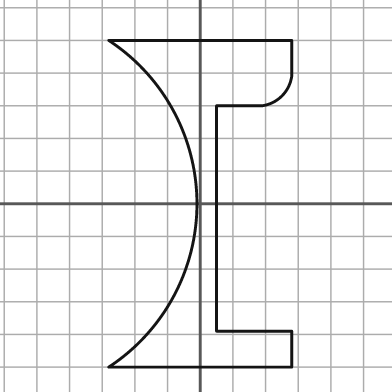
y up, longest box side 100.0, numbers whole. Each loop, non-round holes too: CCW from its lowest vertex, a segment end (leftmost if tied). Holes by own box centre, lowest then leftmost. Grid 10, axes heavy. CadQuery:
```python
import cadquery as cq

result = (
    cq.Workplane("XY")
    .moveTo(-28.0, -50.0)
    .lineTo(28.0, -50.0)
    .lineTo(28.0, -39.0)
    .lineTo(5.0, -39.0)
    .lineTo(5.0, 30.0)
    .lineTo(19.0, 30.0)
    .threePointArc((25.0, 33.0), (28.0, 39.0))
    .lineTo(28.0, 50.0)
    .lineTo(-28.0, 50.0)
    .threePointArc((-1.0, 0.0), (-28.0, -50.0))
    .close()
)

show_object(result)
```